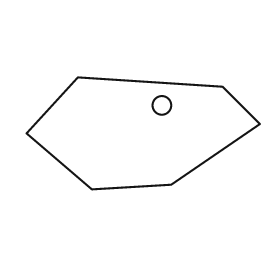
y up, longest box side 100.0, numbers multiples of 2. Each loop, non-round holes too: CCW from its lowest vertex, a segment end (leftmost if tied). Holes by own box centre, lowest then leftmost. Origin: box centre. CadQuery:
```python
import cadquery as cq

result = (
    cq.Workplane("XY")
    .moveTo(-22.0, -24.0)
    .lineTo(12.0, -22.0)
    .lineTo(50.0, 4.0)
    .lineTo(34.0, 20.0)
    .lineTo(-28.0, 24.0)
    .lineTo(-50.0, 0.0)
    .close()
    .moveTo(8.0, 12.0)
    .circle(4.0)
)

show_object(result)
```